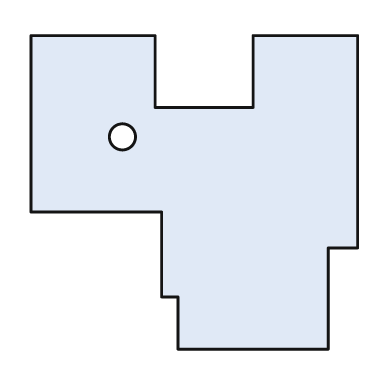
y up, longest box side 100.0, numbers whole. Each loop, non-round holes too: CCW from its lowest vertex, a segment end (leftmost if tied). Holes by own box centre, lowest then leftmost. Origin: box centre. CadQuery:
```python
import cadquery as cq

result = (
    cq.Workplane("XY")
    .moveTo(-5.0, -48.0)
    .lineTo(41.0, -48.0)
    .lineTo(41.0, -17.0)
    .lineTo(50.0, -17.0)
    .lineTo(50.0, 48.0)
    .lineTo(18.0, 48.0)
    .lineTo(18.0, 26.0)
    .lineTo(-12.0, 26.0)
    .lineTo(-12.0, 48.0)
    .lineTo(-50.0, 48.0)
    .lineTo(-50.0, -6.0)
    .lineTo(-10.0, -6.0)
    .lineTo(-10.0, -32.0)
    .lineTo(-5.0, -32.0)
    .close()
    .moveTo(-22.0, 17.0)
    .circle(4.0)
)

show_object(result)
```